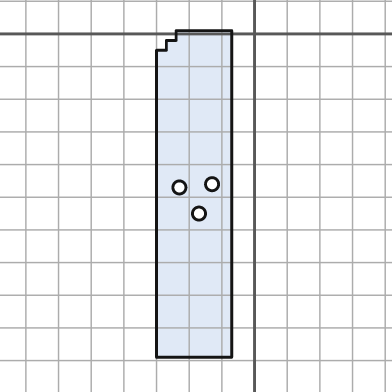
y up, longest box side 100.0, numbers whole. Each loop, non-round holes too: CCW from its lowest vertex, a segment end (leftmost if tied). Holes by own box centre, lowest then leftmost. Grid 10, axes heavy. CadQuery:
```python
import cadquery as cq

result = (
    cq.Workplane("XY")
    .moveTo(-30.0, -99.0)
    .lineTo(-7.0, -99.0)
    .lineTo(-7.0, 1.0)
    .lineTo(-24.0, 1.0)
    .lineTo(-24.0, -2.0)
    .lineTo(-27.0, -2.0)
    .lineTo(-27.0, -5.0)
    .lineTo(-30.0, -5.0)
    .close()
    .moveTo(-17.0, -55.0)
    .circle(2.0)
    .moveTo(-23.0, -47.0)
    .circle(2.0)
    .moveTo(-13.0, -46.0)
    .circle(2.0)
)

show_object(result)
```